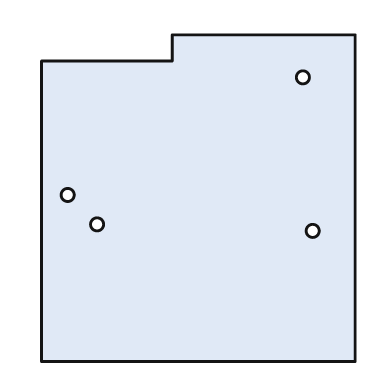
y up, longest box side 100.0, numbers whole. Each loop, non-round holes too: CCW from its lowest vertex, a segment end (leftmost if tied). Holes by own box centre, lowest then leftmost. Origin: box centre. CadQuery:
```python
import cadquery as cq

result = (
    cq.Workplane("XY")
    .moveTo(-48.0, -50.0)
    .lineTo(48.0, -50.0)
    .lineTo(48.0, 50.0)
    .lineTo(-8.0, 50.0)
    .lineTo(-8.0, 42.0)
    .lineTo(-48.0, 42.0)
    .close()
    .moveTo(35.0, -10.0)
    .circle(2.0)
    .moveTo(-31.0, -8.0)
    .circle(2.0)
    .moveTo(-40.0, 1.0)
    .circle(2.0)
    .moveTo(32.0, 37.0)
    .circle(2.0)
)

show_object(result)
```